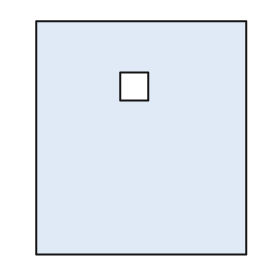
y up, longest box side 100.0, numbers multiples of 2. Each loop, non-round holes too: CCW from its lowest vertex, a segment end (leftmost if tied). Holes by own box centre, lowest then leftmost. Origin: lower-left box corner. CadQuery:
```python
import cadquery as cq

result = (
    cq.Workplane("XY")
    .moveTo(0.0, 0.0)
    .lineTo(90.0, 0.0)
    .lineTo(90.0, 100.0)
    .lineTo(0.0, 100.0)
    .close()
    .moveTo(36.0, 66.0)
    .lineTo(48.0, 66.0)
    .lineTo(48.0, 78.0)
    .lineTo(36.0, 78.0)
    .close()
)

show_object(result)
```